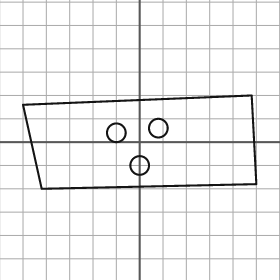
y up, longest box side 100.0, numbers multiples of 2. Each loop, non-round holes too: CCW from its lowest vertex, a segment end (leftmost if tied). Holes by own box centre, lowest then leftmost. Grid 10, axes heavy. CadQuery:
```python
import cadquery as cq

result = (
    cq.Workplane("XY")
    .moveTo(-42.0, -20.0)
    .lineTo(50.0, -18.0)
    .lineTo(48.0, 20.0)
    .lineTo(-50.0, 16.0)
    .close()
    .moveTo(0.0, -10.0)
    .circle(4.0)
    .moveTo(-10.0, 4.0)
    .circle(4.0)
    .moveTo(8.0, 6.0)
    .circle(4.0)
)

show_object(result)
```